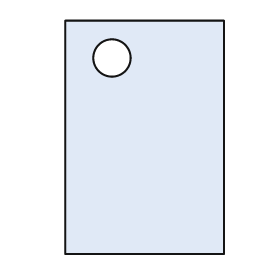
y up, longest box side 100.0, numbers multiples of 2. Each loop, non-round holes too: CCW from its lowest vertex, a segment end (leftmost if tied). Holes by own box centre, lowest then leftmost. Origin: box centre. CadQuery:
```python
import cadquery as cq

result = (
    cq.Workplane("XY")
    .moveTo(-34.0, -50.0)
    .lineTo(34.0, -50.0)
    .lineTo(34.0, 50.0)
    .lineTo(-34.0, 50.0)
    .close()
    .moveTo(-14.0, 34.0)
    .circle(8.0)
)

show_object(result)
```